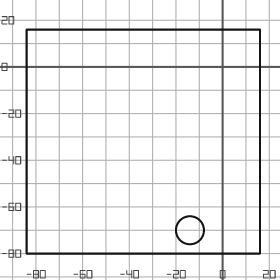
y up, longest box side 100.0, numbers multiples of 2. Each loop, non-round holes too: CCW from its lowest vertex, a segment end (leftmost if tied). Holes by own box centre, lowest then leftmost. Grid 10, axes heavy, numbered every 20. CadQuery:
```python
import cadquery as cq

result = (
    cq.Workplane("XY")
    .moveTo(-84.0, -80.0)
    .lineTo(16.0, -80.0)
    .lineTo(16.0, 16.0)
    .lineTo(-84.0, 16.0)
    .close()
    .moveTo(-14.0, -70.0)
    .circle(6.0)
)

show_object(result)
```